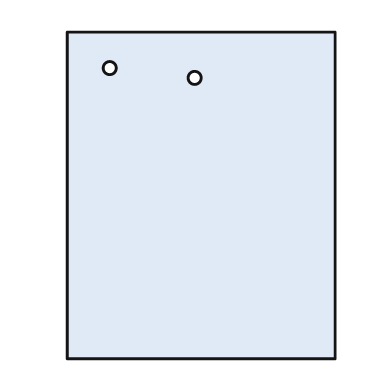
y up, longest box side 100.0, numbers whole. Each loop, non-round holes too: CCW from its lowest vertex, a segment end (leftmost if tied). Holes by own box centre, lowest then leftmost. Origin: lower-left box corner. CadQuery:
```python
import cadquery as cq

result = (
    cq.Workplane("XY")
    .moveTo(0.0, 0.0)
    .lineTo(82.0, 0.0)
    .lineTo(82.0, 100.0)
    .lineTo(0.0, 100.0)
    .close()
    .moveTo(39.0, 86.0)
    .circle(2.0)
    .moveTo(13.0, 89.0)
    .circle(2.0)
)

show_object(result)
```